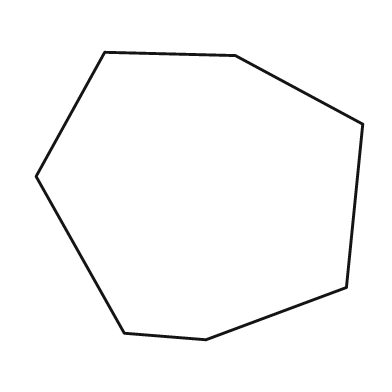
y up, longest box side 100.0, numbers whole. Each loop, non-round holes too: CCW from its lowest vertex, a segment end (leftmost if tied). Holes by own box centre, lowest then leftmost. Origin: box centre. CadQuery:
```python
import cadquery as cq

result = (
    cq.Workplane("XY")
    .moveTo(2.0, -44.0)
    .lineTo(45.0, -28.0)
    .lineTo(50.0, 22.0)
    .lineTo(11.0, 43.0)
    .lineTo(-29.0, 44.0)
    .lineTo(-50.0, 6.0)
    .lineTo(-23.0, -42.0)
    .close()
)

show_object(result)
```